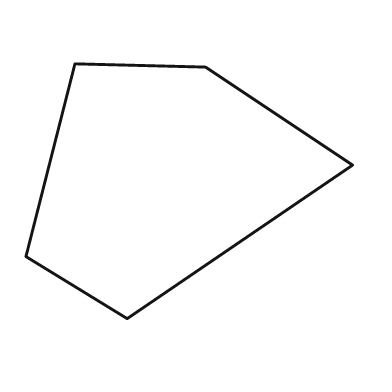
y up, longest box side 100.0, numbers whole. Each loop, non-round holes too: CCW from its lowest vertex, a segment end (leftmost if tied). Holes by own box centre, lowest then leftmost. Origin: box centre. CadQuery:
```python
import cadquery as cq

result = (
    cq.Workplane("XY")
    .moveTo(-19.0, -39.0)
    .lineTo(50.0, 8.0)
    .lineTo(5.0, 38.0)
    .lineTo(-35.0, 39.0)
    .lineTo(-50.0, -20.0)
    .close()
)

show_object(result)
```